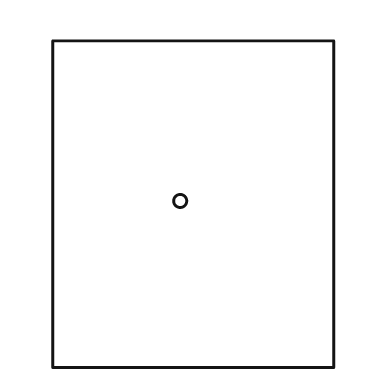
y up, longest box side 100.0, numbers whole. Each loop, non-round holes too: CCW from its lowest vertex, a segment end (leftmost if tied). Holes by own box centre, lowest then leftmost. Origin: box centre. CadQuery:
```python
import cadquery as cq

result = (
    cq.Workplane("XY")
    .moveTo(-43.0, -50.0)
    .lineTo(43.0, -50.0)
    .lineTo(43.0, 50.0)
    .lineTo(-43.0, 50.0)
    .close()
    .moveTo(-4.0, 1.0)
    .circle(2.0)
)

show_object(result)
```